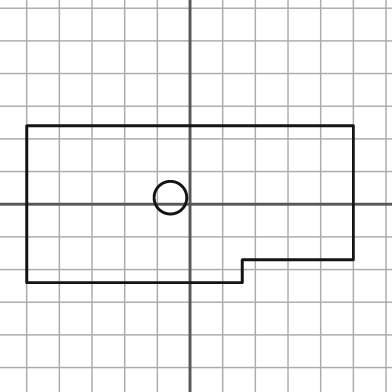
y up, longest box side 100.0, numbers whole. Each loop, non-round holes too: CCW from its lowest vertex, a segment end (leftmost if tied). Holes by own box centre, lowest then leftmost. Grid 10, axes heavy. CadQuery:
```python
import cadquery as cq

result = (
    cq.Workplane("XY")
    .moveTo(-50.0, -24.0)
    .lineTo(16.0, -24.0)
    .lineTo(16.0, -17.0)
    .lineTo(50.0, -17.0)
    .lineTo(50.0, 24.0)
    .lineTo(-50.0, 24.0)
    .close()
    .moveTo(-6.0, 2.0)
    .circle(5.0)
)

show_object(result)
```